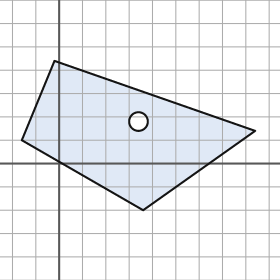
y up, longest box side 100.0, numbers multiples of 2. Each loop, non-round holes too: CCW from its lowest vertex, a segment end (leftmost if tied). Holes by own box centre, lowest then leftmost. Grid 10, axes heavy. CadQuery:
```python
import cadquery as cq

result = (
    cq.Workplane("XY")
    .moveTo(36.0, -20.0)
    .lineTo(84.0, 14.0)
    .lineTo(-2.0, 44.0)
    .lineTo(-16.0, 10.0)
    .close()
    .moveTo(34.0, 18.0)
    .circle(4.0)
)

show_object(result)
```